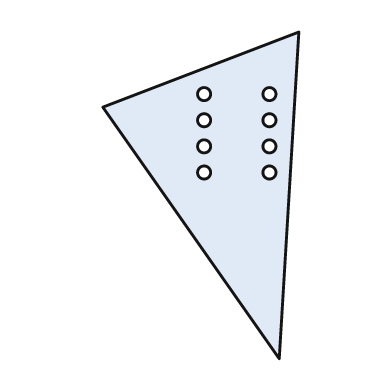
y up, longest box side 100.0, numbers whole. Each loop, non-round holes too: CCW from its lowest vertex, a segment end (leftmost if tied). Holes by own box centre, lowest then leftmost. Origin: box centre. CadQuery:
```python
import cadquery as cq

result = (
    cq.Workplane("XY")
    .moveTo(24.0, -50.0)
    .lineTo(30.0, 50.0)
    .lineTo(-30.0, 27.0)
    .close()
    .moveTo(1.0, 7.0)
    .circle(2.0)
    .moveTo(21.0, 7.0)
    .circle(2.0)
    .moveTo(1.0, 15.0)
    .circle(2.0)
    .moveTo(21.0, 15.0)
    .circle(2.0)
    .moveTo(1.0, 23.0)
    .circle(2.0)
    .moveTo(21.0, 23.0)
    .circle(2.0)
    .moveTo(1.0, 31.0)
    .circle(2.0)
    .moveTo(21.0, 31.0)
    .circle(2.0)
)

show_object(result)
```